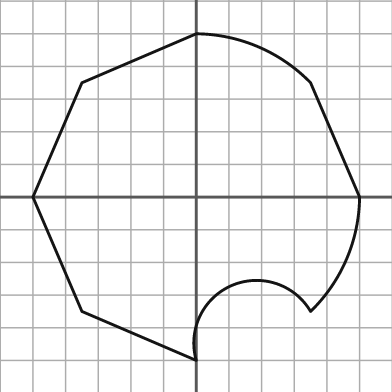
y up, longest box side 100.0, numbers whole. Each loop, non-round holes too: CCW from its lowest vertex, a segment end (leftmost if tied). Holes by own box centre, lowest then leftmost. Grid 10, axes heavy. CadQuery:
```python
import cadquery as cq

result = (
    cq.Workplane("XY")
    .moveTo(0.0, -50.0)
    .threePointArc((11.0, -27.0), (35.0, -35.0))
    .threePointArc((46.0, -19.0), (50.0, 0.0))
    .lineTo(35.0, 35.0)
    .threePointArc((19.0, 46.0), (0.0, 50.0))
    .lineTo(-35.0, 35.0)
    .lineTo(-50.0, 0.0)
    .lineTo(-35.0, -35.0)
    .close()
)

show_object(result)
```